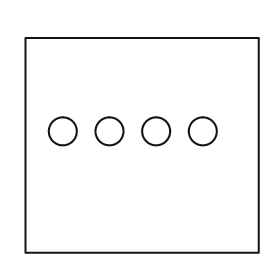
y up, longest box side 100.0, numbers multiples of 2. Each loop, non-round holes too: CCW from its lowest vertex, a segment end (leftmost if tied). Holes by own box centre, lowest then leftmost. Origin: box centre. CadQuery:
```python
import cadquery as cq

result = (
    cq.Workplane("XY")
    .moveTo(-50.0, -46.0)
    .lineTo(50.0, -46.0)
    .lineTo(50.0, 46.0)
    .lineTo(-50.0, 46.0)
    .close()
    .moveTo(-34.0, 6.0)
    .circle(6.0)
    .moveTo(-14.0, 6.0)
    .circle(6.0)
    .moveTo(6.0, 6.0)
    .circle(6.0)
    .moveTo(26.0, 6.0)
    .circle(6.0)
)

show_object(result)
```